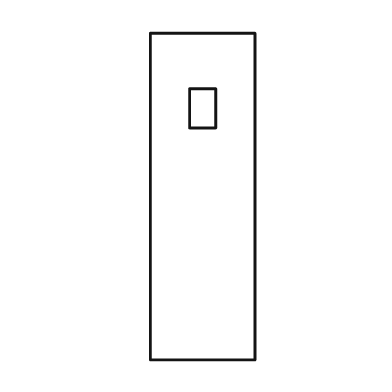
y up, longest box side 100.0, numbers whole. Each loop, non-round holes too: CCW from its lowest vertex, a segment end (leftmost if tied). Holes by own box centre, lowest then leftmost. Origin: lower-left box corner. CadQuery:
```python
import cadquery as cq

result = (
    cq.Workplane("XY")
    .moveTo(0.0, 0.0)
    .lineTo(32.0, 0.0)
    .lineTo(32.0, 100.0)
    .lineTo(0.0, 100.0)
    .close()
    .moveTo(12.0, 71.0)
    .lineTo(20.0, 71.0)
    .lineTo(20.0, 83.0)
    .lineTo(12.0, 83.0)
    .close()
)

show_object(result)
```